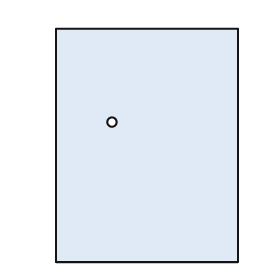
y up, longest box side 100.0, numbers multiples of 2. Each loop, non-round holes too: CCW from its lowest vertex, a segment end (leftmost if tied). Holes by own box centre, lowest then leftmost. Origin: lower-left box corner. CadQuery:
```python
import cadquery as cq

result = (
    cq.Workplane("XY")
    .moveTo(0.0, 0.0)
    .lineTo(78.0, 0.0)
    .lineTo(78.0, 100.0)
    .lineTo(0.0, 100.0)
    .close()
    .moveTo(24.0, 60.0)
    .circle(2.0)
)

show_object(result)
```